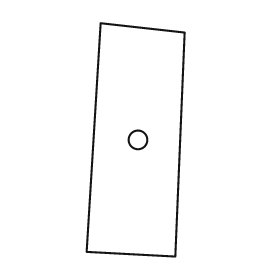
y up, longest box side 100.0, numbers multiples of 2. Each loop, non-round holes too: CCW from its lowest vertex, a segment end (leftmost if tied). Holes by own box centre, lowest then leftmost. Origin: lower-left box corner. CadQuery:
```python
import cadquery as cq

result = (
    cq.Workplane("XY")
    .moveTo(38.0, 0.0)
    .lineTo(42.0, 96.0)
    .lineTo(6.0, 100.0)
    .lineTo(0.0, 2.0)
    .close()
    .moveTo(22.0, 50.0)
    .circle(4.0)
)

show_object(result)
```